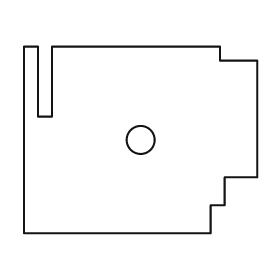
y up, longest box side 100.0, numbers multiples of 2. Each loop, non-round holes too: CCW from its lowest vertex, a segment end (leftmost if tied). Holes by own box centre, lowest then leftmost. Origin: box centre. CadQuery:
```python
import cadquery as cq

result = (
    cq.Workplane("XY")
    .moveTo(-50.0, -40.0)
    .lineTo(30.0, -40.0)
    .lineTo(30.0, -28.0)
    .lineTo(36.0, -28.0)
    .lineTo(36.0, -16.0)
    .lineTo(50.0, -16.0)
    .lineTo(50.0, 34.0)
    .lineTo(34.0, 34.0)
    .lineTo(34.0, 40.0)
    .lineTo(-38.0, 40.0)
    .lineTo(-38.0, 10.0)
    .lineTo(-44.0, 10.0)
    .lineTo(-44.0, 40.0)
    .lineTo(-50.0, 40.0)
    .close()
    .moveTo(0.0, 0.0)
    .circle(6.0)
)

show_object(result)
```